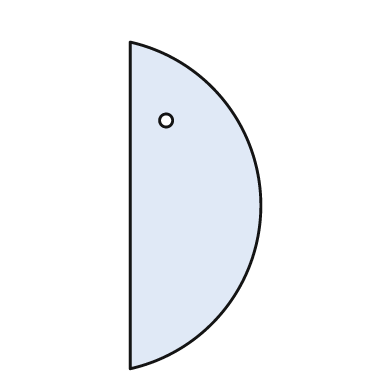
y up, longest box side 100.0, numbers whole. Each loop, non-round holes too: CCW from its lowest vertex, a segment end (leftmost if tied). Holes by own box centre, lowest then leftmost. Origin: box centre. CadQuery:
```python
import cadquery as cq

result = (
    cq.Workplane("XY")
    .moveTo(-20.0, -50.0)
    .threePointArc((20.0, 0.0), (-20.0, 50.0))
    .close()
    .moveTo(-9.0, 26.0)
    .circle(2.0)
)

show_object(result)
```